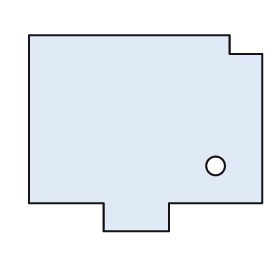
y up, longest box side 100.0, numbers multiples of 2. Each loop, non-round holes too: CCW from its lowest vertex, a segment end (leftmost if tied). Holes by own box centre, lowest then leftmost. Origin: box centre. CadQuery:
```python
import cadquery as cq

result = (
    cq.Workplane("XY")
    .moveTo(-18.0, -42.0)
    .lineTo(10.0, -42.0)
    .lineTo(10.0, -30.0)
    .lineTo(50.0, -30.0)
    .lineTo(50.0, 34.0)
    .lineTo(36.0, 34.0)
    .lineTo(36.0, 42.0)
    .lineTo(-50.0, 42.0)
    .lineTo(-50.0, -30.0)
    .lineTo(-18.0, -30.0)
    .close()
    .moveTo(30.0, -14.0)
    .circle(4.0)
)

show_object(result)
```